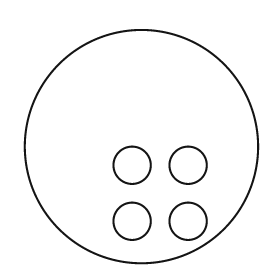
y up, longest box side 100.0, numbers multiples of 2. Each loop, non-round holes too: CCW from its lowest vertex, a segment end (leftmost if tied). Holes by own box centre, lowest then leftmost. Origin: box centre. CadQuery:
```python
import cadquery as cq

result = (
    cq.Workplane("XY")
    .moveTo(0.0, 0.0)
    .circle(50.0)
    .moveTo(-4.0, -32.0)
    .circle(8.0)
    .moveTo(20.0, -32.0)
    .circle(8.0)
    .moveTo(-4.0, -8.0)
    .circle(8.0)
    .moveTo(20.0, -8.0)
    .circle(8.0)
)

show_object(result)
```